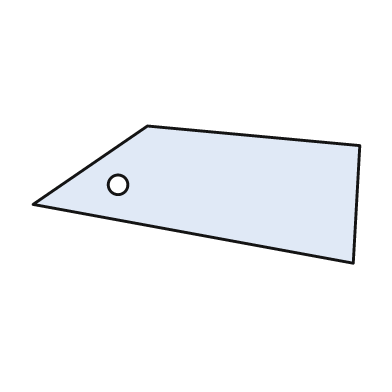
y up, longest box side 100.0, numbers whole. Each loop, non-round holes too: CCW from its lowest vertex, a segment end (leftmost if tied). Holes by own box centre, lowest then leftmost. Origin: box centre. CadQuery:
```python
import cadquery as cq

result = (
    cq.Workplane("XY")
    .moveTo(48.0, -21.0)
    .lineTo(50.0, 15.0)
    .lineTo(-15.0, 21.0)
    .lineTo(-50.0, -3.0)
    .close()
    .moveTo(-24.0, 3.0)
    .circle(3.0)
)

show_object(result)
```